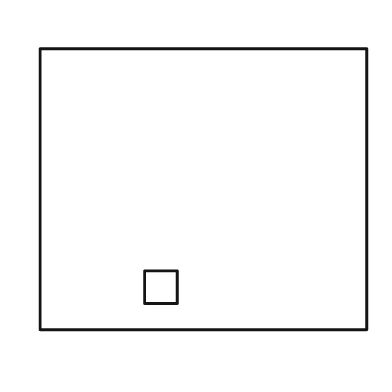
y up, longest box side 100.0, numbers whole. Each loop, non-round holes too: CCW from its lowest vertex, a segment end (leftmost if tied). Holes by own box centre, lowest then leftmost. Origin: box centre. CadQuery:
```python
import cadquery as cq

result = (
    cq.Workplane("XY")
    .moveTo(-50.0, -43.0)
    .lineTo(50.0, -43.0)
    .lineTo(50.0, 43.0)
    .lineTo(-50.0, 43.0)
    .close()
    .moveTo(-18.0, -35.0)
    .lineTo(-8.0, -35.0)
    .lineTo(-8.0, -25.0)
    .lineTo(-18.0, -25.0)
    .close()
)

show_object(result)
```